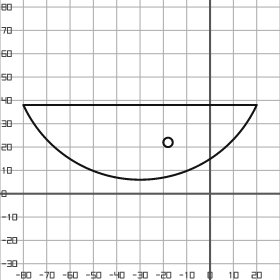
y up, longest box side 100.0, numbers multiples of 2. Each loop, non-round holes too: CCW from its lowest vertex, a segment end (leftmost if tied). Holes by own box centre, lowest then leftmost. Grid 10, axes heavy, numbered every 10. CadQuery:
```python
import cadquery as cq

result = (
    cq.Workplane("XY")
    .moveTo(-80.0, 38.0)
    .threePointArc((-30.0, 6.0), (20.0, 38.0))
    .close()
    .moveTo(-18.0, 22.0)
    .circle(2.0)
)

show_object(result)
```